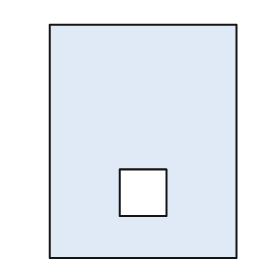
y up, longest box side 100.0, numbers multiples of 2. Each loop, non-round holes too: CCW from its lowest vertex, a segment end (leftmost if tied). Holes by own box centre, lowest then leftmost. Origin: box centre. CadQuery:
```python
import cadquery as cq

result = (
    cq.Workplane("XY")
    .moveTo(-40.0, -50.0)
    .lineTo(40.0, -50.0)
    .lineTo(40.0, 50.0)
    .lineTo(-40.0, 50.0)
    .close()
    .moveTo(-10.0, -32.0)
    .lineTo(10.0, -32.0)
    .lineTo(10.0, -12.0)
    .lineTo(-10.0, -12.0)
    .close()
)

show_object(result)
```